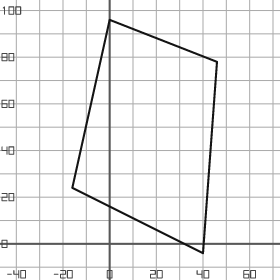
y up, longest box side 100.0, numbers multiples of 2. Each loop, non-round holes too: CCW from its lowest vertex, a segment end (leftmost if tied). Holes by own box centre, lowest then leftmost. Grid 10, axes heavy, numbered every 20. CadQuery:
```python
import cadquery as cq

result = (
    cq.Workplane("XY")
    .moveTo(40.0, -4.0)
    .lineTo(46.0, 78.0)
    .lineTo(0.0, 96.0)
    .lineTo(-16.0, 24.0)
    .close()
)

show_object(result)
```